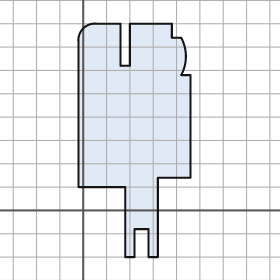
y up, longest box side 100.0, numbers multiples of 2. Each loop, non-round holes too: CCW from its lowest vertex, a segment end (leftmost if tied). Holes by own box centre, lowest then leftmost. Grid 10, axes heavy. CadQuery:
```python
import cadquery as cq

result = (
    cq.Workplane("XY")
    .moveTo(18.0, -20.0)
    .lineTo(22.0, -20.0)
    .lineTo(22.0, -8.0)
    .lineTo(28.0, -8.0)
    .lineTo(28.0, -20.0)
    .lineTo(32.0, -20.0)
    .lineTo(32.0, 14.0)
    .lineTo(46.0, 14.0)
    .lineTo(46.0, 58.0)
    .lineTo(42.0, 58.0)
    .threePointArc((44.0, 66.0), (42.0, 74.0))
    .lineTo(38.0, 74.0)
    .lineTo(38.0, 80.0)
    .lineTo(20.0, 80.0)
    .lineTo(20.0, 62.0)
    .lineTo(16.0, 62.0)
    .lineTo(16.0, 80.0)
    .lineTo(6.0, 80.0)
    .threePointArc((0.0, 78.0), (-2.0, 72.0))
    .lineTo(-2.0, 10.0)
    .lineTo(18.0, 10.0)
    .close()
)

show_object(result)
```